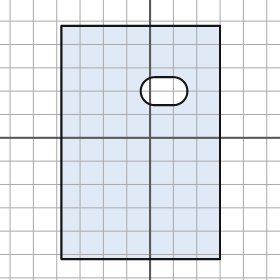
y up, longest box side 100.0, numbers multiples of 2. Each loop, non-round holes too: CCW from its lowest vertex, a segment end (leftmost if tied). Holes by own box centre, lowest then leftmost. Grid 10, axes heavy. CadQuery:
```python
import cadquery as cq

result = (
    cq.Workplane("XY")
    .moveTo(-38.0, -52.0)
    .lineTo(30.0, -52.0)
    .lineTo(30.0, 48.0)
    .lineTo(-38.0, 48.0)
    .close()
    .moveTo(2.0, 14.0)
    .lineTo(10.0, 14.0)
    .threePointArc((16.0, 20.0), (10.0, 26.0))
    .lineTo(2.0, 26.0)
    .threePointArc((-4.0, 20.0), (2.0, 14.0))
    .close()
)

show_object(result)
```